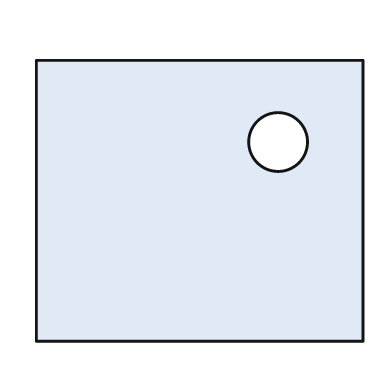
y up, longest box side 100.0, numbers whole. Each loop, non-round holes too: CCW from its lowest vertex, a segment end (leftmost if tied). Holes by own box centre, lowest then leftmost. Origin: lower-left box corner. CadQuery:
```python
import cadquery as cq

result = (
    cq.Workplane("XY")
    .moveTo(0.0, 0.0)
    .lineTo(100.0, 0.0)
    .lineTo(100.0, 86.0)
    .lineTo(0.0, 86.0)
    .close()
    .moveTo(74.0, 61.0)
    .circle(9.0)
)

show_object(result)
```